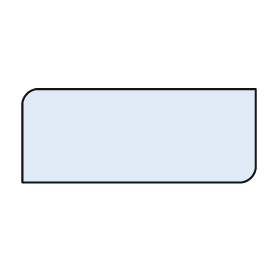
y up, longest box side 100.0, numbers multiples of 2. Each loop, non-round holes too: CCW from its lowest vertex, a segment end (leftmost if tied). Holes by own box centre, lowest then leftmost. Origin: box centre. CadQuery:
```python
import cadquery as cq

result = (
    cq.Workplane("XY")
    .moveTo(-50.0, -20.0)
    .lineTo(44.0, -20.0)
    .threePointArc((48.0, -18.0), (50.0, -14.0))
    .lineTo(50.0, 20.0)
    .lineTo(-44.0, 20.0)
    .threePointArc((-48.0, 18.0), (-50.0, 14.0))
    .close()
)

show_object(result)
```